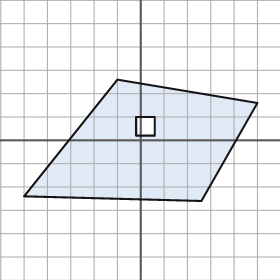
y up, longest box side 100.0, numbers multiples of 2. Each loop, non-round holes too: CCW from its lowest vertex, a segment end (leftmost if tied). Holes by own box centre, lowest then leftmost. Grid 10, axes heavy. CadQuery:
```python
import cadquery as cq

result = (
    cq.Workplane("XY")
    .moveTo(26.0, -26.0)
    .lineTo(50.0, 16.0)
    .lineTo(-10.0, 26.0)
    .lineTo(-50.0, -24.0)
    .close()
    .moveTo(-2.0, 2.0)
    .lineTo(6.0, 2.0)
    .lineTo(6.0, 10.0)
    .lineTo(-2.0, 10.0)
    .close()
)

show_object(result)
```